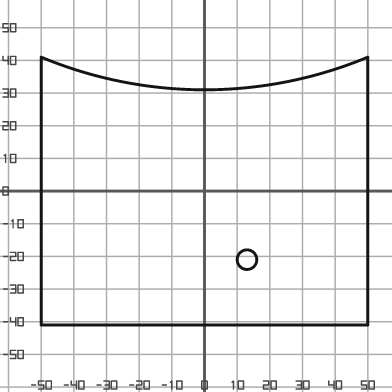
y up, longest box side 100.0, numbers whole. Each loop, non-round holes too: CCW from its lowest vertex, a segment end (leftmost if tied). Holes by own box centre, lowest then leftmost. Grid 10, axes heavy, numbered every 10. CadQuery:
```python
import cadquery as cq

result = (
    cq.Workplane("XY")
    .moveTo(-50.0, -41.0)
    .lineTo(50.0, -41.0)
    .lineTo(50.0, 41.0)
    .threePointArc((0.0, 31.0), (-50.0, 41.0))
    .close()
    .moveTo(13.0, -21.0)
    .circle(3.0)
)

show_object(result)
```